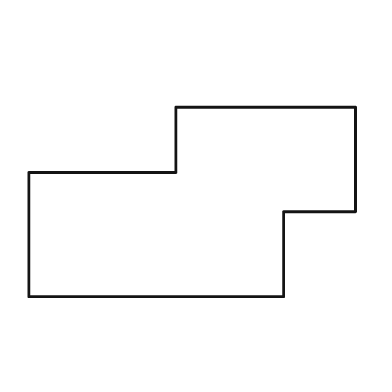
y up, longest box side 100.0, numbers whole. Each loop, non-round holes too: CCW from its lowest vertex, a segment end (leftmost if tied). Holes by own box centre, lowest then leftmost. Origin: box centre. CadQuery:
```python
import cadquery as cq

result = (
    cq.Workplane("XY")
    .moveTo(-50.0, -29.0)
    .lineTo(28.0, -29.0)
    .lineTo(28.0, -3.0)
    .lineTo(50.0, -3.0)
    .lineTo(50.0, 29.0)
    .lineTo(-5.0, 29.0)
    .lineTo(-5.0, 9.0)
    .lineTo(-50.0, 9.0)
    .close()
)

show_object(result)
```